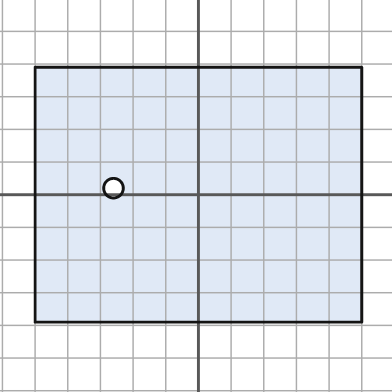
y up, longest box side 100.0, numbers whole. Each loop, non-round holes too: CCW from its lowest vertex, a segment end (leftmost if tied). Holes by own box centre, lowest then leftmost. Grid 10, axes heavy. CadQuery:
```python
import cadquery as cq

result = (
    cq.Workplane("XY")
    .moveTo(-50.0, -39.0)
    .lineTo(50.0, -39.0)
    .lineTo(50.0, 39.0)
    .lineTo(-50.0, 39.0)
    .close()
    .moveTo(-26.0, 2.0)
    .circle(3.0)
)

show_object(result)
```